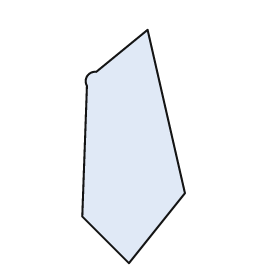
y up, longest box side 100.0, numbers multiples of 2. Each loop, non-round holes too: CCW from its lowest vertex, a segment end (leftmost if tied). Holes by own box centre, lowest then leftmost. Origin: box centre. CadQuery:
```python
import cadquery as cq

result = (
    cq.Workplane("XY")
    .moveTo(-2.0, -50.0)
    .lineTo(22.0, -20.0)
    .lineTo(6.0, 50.0)
    .lineTo(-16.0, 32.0)
    .threePointArc((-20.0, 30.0), (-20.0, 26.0))
    .lineTo(-22.0, -30.0)
    .close()
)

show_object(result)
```